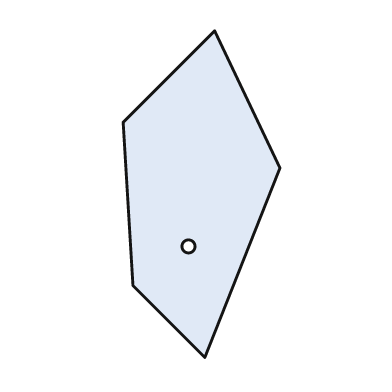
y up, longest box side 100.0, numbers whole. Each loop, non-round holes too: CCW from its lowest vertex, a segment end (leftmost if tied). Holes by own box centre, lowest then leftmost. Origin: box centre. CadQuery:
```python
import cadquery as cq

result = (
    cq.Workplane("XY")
    .moveTo(1.0, -50.0)
    .lineTo(24.0, 8.0)
    .lineTo(4.0, 50.0)
    .lineTo(-24.0, 22.0)
    .lineTo(-21.0, -28.0)
    .close()
    .moveTo(-4.0, -16.0)
    .circle(2.0)
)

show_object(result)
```